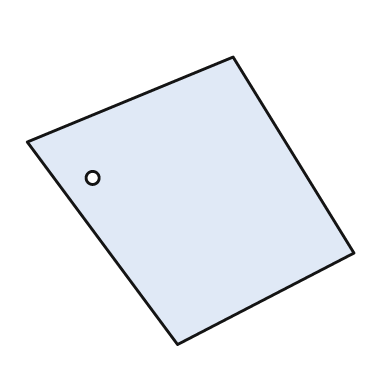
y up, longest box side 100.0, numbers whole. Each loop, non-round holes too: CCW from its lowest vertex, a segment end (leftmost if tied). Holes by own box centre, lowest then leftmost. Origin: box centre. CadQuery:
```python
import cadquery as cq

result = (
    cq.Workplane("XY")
    .moveTo(-4.0, -44.0)
    .lineTo(50.0, -16.0)
    .lineTo(13.0, 44.0)
    .lineTo(-50.0, 18.0)
    .close()
    .moveTo(-30.0, 7.0)
    .circle(2.0)
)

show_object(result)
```